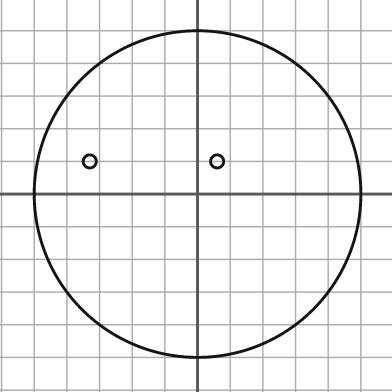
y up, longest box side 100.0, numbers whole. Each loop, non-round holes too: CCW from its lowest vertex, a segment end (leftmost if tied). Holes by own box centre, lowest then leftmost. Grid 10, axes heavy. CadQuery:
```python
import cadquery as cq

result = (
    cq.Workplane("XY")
    .moveTo(0.0, 0.0)
    .circle(50.0)
    .moveTo(-33.0, 10.0)
    .circle(2.0)
    .moveTo(6.0, 10.0)
    .circle(2.0)
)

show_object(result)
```